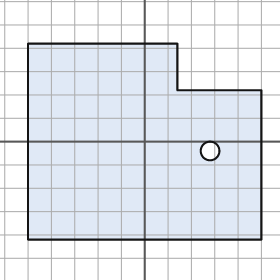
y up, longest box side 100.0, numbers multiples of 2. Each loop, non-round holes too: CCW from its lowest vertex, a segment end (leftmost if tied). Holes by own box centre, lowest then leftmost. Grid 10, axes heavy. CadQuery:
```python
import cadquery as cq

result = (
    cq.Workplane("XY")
    .moveTo(-50.0, -42.0)
    .lineTo(50.0, -42.0)
    .lineTo(50.0, 22.0)
    .lineTo(14.0, 22.0)
    .lineTo(14.0, 42.0)
    .lineTo(-50.0, 42.0)
    .close()
    .moveTo(28.0, -4.0)
    .circle(4.0)
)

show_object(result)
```